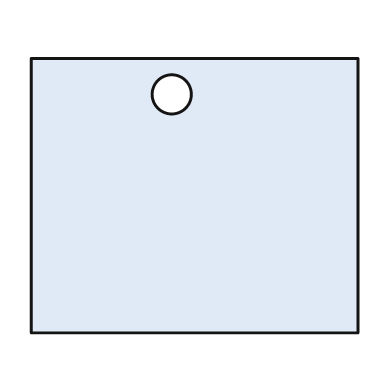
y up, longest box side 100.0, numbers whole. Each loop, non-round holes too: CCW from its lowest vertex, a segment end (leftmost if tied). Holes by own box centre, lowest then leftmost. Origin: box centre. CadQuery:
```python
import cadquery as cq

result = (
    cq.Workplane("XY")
    .moveTo(-50.0, -42.0)
    .lineTo(50.0, -42.0)
    .lineTo(50.0, 42.0)
    .lineTo(-50.0, 42.0)
    .close()
    .moveTo(-7.0, 31.0)
    .circle(6.0)
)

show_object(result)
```